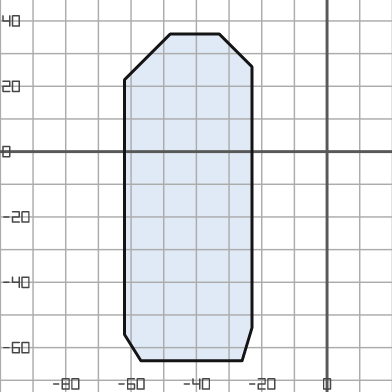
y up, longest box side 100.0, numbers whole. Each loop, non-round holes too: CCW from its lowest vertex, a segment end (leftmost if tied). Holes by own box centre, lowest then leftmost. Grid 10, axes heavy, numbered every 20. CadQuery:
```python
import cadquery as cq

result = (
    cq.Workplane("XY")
    .moveTo(-57.0, -64.0)
    .lineTo(-26.0, -64.0)
    .lineTo(-23.0, -54.0)
    .lineTo(-23.0, 26.0)
    .lineTo(-33.0, 36.0)
    .lineTo(-48.0, 36.0)
    .lineTo(-62.0, 22.0)
    .lineTo(-62.0, -56.0)
    .close()
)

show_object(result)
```